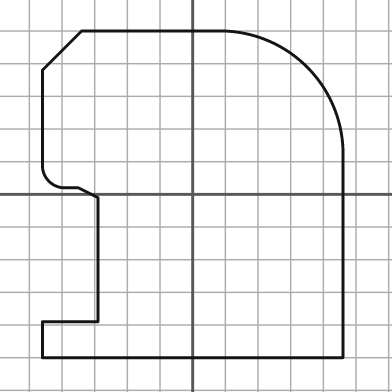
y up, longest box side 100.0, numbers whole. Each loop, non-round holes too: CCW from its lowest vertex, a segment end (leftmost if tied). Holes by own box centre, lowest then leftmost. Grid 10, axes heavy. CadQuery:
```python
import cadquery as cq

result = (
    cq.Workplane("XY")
    .moveTo(-46.0, -50.0)
    .lineTo(46.0, -50.0)
    .lineTo(46.0, 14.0)
    .threePointArc((35.0, 39.0), (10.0, 50.0))
    .lineTo(-34.0, 50.0)
    .lineTo(-46.0, 38.0)
    .lineTo(-46.0, 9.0)
    .threePointArc((-44.0, 4.0), (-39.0, 2.0))
    .lineTo(-35.0, 2.0)
    .lineTo(-29.0, -1.0)
    .lineTo(-29.0, -39.0)
    .lineTo(-46.0, -39.0)
    .close()
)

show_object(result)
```